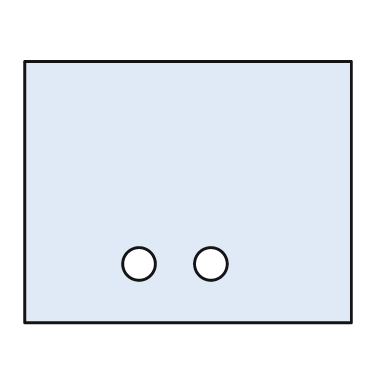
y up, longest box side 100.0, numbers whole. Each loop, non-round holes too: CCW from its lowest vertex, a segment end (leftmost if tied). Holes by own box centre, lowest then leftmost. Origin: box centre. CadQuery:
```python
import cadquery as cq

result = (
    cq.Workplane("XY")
    .moveTo(-50.0, -40.0)
    .lineTo(50.0, -40.0)
    .lineTo(50.0, 40.0)
    .lineTo(-50.0, 40.0)
    .close()
    .moveTo(-15.0, -22.0)
    .circle(5.0)
    .moveTo(7.0, -22.0)
    .circle(5.0)
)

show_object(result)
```